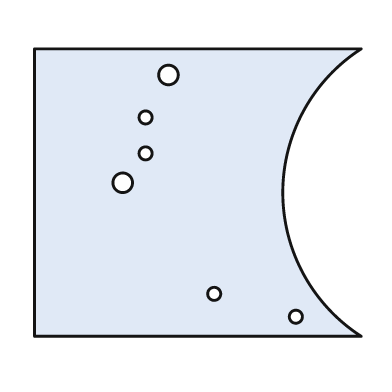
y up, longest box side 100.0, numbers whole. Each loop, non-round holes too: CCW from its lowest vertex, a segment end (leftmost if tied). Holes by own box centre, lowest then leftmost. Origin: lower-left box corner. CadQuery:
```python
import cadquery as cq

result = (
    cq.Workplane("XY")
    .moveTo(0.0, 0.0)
    .lineTo(100.0, 0.0)
    .threePointArc((76.0, 44.0), (100.0, 88.0))
    .lineTo(0.0, 88.0)
    .close()
    .moveTo(80.0, 6.0)
    .circle(2.0)
    .moveTo(55.0, 13.0)
    .circle(2.0)
    .moveTo(27.0, 47.0)
    .circle(3.0)
    .moveTo(34.0, 56.0)
    .circle(2.0)
    .moveTo(34.0, 67.0)
    .circle(2.0)
    .moveTo(41.0, 80.0)
    .circle(3.0)
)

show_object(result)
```